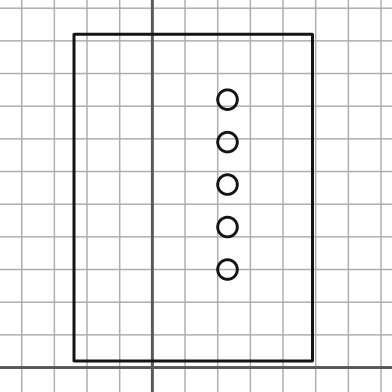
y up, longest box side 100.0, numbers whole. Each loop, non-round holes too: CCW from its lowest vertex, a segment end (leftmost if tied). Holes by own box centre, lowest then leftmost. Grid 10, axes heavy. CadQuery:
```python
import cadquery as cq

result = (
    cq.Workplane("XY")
    .moveTo(-24.0, 2.0)
    .lineTo(49.0, 2.0)
    .lineTo(49.0, 102.0)
    .lineTo(-24.0, 102.0)
    .close()
    .moveTo(23.0, 30.0)
    .circle(3.0)
    .moveTo(23.0, 43.0)
    .circle(3.0)
    .moveTo(23.0, 56.0)
    .circle(3.0)
    .moveTo(23.0, 69.0)
    .circle(3.0)
    .moveTo(23.0, 82.0)
    .circle(3.0)
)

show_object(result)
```